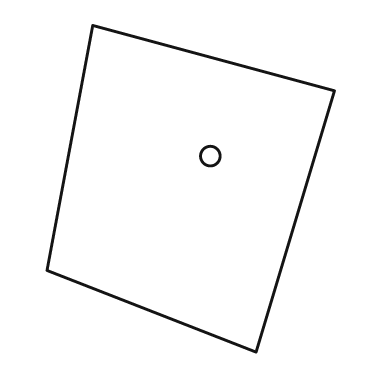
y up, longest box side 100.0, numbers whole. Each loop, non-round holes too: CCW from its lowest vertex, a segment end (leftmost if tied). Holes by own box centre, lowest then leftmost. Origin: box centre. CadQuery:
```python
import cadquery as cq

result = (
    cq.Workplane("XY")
    .moveTo(20.0, -50.0)
    .lineTo(44.0, 30.0)
    .lineTo(-30.0, 50.0)
    .lineTo(-44.0, -25.0)
    .close()
    .moveTo(6.0, 10.0)
    .circle(3.0)
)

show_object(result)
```